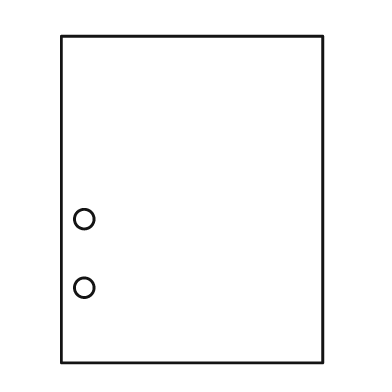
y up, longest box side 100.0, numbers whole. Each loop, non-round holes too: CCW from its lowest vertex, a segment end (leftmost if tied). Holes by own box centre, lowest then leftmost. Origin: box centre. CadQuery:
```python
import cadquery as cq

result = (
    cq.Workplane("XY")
    .moveTo(-40.0, -50.0)
    .lineTo(40.0, -50.0)
    .lineTo(40.0, 50.0)
    .lineTo(-40.0, 50.0)
    .close()
    .moveTo(-33.0, -27.0)
    .circle(3.0)
    .moveTo(-33.0, -6.0)
    .circle(3.0)
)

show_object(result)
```